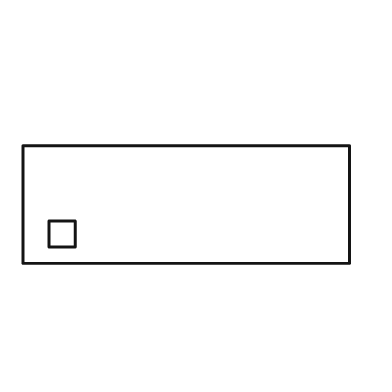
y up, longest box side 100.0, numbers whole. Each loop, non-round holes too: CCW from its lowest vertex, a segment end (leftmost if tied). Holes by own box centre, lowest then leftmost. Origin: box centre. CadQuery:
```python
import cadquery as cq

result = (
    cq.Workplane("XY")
    .moveTo(-50.0, -18.0)
    .lineTo(50.0, -18.0)
    .lineTo(50.0, 18.0)
    .lineTo(-50.0, 18.0)
    .close()
    .moveTo(-42.0, -13.0)
    .lineTo(-34.0, -13.0)
    .lineTo(-34.0, -5.0)
    .lineTo(-42.0, -5.0)
    .close()
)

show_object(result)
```